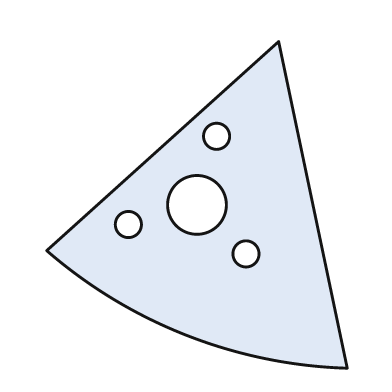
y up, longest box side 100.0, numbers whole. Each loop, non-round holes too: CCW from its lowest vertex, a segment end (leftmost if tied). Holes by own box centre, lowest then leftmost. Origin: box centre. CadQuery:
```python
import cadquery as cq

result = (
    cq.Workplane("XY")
    .moveTo(46.0, -50.0)
    .lineTo(25.0, 50.0)
    .lineTo(-46.0, -14.0)
    .threePointArc((-3.0, -40.0), (46.0, -50.0))
    .close()
    .moveTo(15.0, -15.0)
    .circle(4.0)
    .moveTo(-21.0, -6.0)
    .circle(4.0)
    .moveTo(0.0, 0.0)
    .circle(9.0)
    .moveTo(6.0, 21.0)
    .circle(4.0)
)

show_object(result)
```